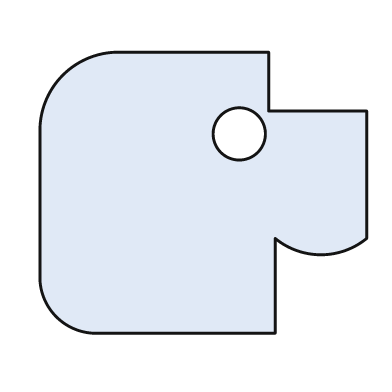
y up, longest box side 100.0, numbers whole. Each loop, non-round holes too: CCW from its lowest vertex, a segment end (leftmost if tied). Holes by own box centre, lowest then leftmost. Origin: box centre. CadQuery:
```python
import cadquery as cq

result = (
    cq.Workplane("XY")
    .moveTo(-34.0, -43.0)
    .lineTo(22.0, -43.0)
    .lineTo(22.0, -14.0)
    .threePointArc((36.0, -19.0), (50.0, -14.0))
    .lineTo(50.0, 25.0)
    .lineTo(20.0, 25.0)
    .lineTo(20.0, 43.0)
    .lineTo(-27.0, 43.0)
    .threePointArc((-43.0, 36.0), (-50.0, 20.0))
    .lineTo(-50.0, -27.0)
    .threePointArc((-45.0, -38.0), (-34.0, -43.0))
    .close()
    .moveTo(11.0, 18.0)
    .circle(8.0)
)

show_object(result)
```